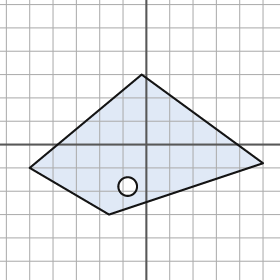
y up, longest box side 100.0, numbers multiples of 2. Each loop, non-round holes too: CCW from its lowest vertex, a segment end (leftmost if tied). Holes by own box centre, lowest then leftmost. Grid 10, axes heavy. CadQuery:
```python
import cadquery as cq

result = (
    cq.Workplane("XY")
    .moveTo(-16.0, -30.0)
    .lineTo(50.0, -8.0)
    .lineTo(-2.0, 30.0)
    .lineTo(-50.0, -10.0)
    .close()
    .moveTo(-8.0, -18.0)
    .circle(4.0)
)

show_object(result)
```